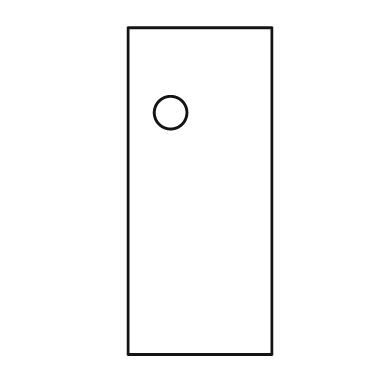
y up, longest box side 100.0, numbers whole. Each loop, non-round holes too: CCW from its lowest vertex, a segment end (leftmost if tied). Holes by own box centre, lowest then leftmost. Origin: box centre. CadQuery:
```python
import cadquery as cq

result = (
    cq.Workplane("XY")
    .moveTo(-22.0, -50.0)
    .lineTo(22.0, -50.0)
    .lineTo(22.0, 50.0)
    .lineTo(-22.0, 50.0)
    .close()
    .moveTo(-9.0, 24.0)
    .circle(5.0)
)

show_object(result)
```